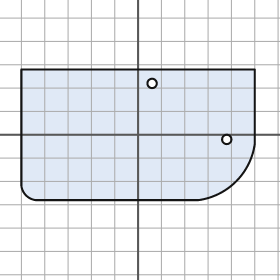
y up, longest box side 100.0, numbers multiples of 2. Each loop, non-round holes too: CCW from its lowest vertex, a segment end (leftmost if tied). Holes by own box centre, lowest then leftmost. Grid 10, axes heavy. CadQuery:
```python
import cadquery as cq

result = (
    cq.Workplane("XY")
    .moveTo(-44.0, -28.0)
    .lineTo(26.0, -28.0)
    .threePointArc((42.0, -20.0), (50.0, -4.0))
    .lineTo(50.0, 28.0)
    .lineTo(-50.0, 28.0)
    .lineTo(-50.0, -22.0)
    .threePointArc((-48.0, -26.0), (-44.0, -28.0))
    .close()
    .moveTo(38.0, -2.0)
    .circle(2.0)
    .moveTo(6.0, 22.0)
    .circle(2.0)
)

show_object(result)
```